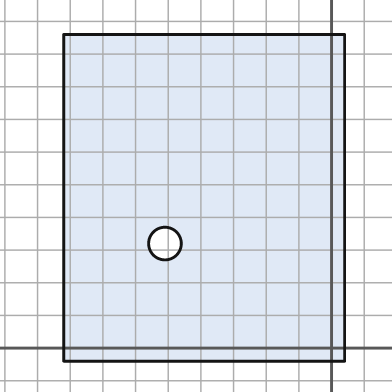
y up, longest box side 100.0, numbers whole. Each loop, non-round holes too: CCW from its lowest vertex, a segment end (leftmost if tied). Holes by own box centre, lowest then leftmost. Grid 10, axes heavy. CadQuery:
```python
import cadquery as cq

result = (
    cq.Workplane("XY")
    .moveTo(-82.0, -4.0)
    .lineTo(4.0, -4.0)
    .lineTo(4.0, 96.0)
    .lineTo(-82.0, 96.0)
    .close()
    .moveTo(-51.0, 32.0)
    .circle(5.0)
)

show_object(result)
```